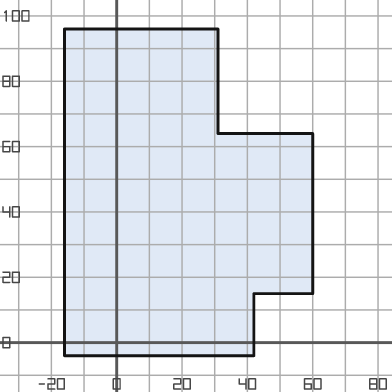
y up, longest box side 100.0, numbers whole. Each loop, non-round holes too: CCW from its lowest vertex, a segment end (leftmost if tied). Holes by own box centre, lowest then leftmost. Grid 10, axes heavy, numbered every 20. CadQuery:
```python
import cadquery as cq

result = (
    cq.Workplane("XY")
    .moveTo(-16.0, -4.0)
    .lineTo(42.0, -4.0)
    .lineTo(42.0, 15.0)
    .lineTo(60.0, 15.0)
    .lineTo(60.0, 64.0)
    .lineTo(31.0, 64.0)
    .lineTo(31.0, 96.0)
    .lineTo(-16.0, 96.0)
    .close()
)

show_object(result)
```